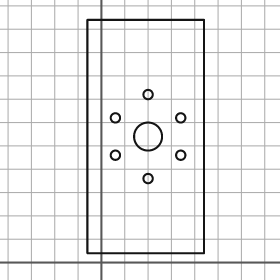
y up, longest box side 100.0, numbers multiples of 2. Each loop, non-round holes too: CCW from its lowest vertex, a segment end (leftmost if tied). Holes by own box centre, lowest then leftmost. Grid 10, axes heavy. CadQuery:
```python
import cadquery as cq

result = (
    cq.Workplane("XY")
    .moveTo(-6.0, 4.0)
    .lineTo(44.0, 4.0)
    .lineTo(44.0, 104.0)
    .lineTo(-6.0, 104.0)
    .close()
    .moveTo(20.0, 36.0)
    .circle(2.0)
    .moveTo(6.0, 46.0)
    .circle(2.0)
    .moveTo(34.0, 46.0)
    .circle(2.0)
    .moveTo(20.0, 54.0)
    .circle(6.0)
    .moveTo(6.0, 62.0)
    .circle(2.0)
    .moveTo(34.0, 62.0)
    .circle(2.0)
    .moveTo(20.0, 72.0)
    .circle(2.0)
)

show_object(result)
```